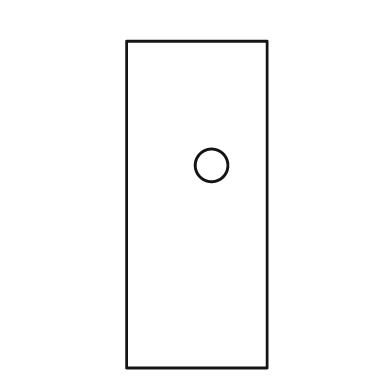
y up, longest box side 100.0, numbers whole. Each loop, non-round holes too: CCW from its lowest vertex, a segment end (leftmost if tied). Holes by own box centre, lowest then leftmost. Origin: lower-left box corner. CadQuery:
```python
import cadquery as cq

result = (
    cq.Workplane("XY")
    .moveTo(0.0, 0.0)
    .lineTo(43.0, 0.0)
    .lineTo(43.0, 100.0)
    .lineTo(0.0, 100.0)
    .close()
    .moveTo(26.0, 62.0)
    .circle(5.0)
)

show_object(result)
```